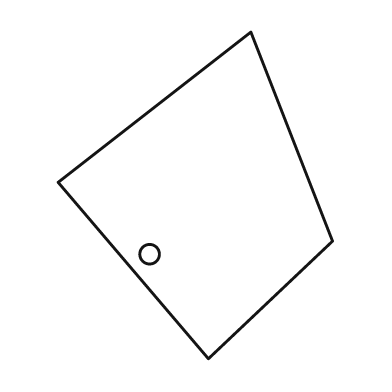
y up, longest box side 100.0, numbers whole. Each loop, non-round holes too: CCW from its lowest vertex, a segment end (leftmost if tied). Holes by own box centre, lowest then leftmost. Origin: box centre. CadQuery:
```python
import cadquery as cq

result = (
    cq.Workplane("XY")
    .moveTo(4.0, -50.0)
    .lineTo(42.0, -14.0)
    .lineTo(17.0, 50.0)
    .lineTo(-42.0, 4.0)
    .close()
    .moveTo(-14.0, -18.0)
    .circle(3.0)
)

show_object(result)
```